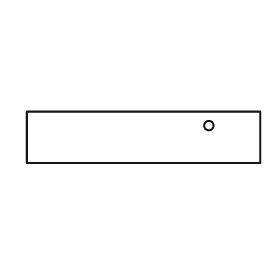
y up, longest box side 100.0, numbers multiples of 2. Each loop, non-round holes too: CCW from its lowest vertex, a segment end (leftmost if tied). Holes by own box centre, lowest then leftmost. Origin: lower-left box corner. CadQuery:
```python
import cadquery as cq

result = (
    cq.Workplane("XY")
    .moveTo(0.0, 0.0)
    .lineTo(100.0, 0.0)
    .lineTo(100.0, 22.0)
    .lineTo(0.0, 22.0)
    .close()
    .moveTo(78.0, 16.0)
    .circle(2.0)
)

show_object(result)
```